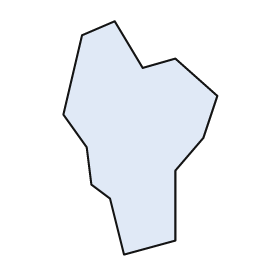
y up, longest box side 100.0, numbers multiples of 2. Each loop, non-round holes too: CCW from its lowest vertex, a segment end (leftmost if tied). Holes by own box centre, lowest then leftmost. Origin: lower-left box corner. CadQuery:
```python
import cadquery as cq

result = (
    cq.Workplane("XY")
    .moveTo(26.0, 0.0)
    .lineTo(48.0, 6.0)
    .lineTo(48.0, 36.0)
    .lineTo(60.0, 50.0)
    .lineTo(66.0, 68.0)
    .lineTo(48.0, 84.0)
    .lineTo(34.0, 80.0)
    .lineTo(22.0, 100.0)
    .lineTo(8.0, 94.0)
    .lineTo(0.0, 60.0)
    .lineTo(10.0, 46.0)
    .lineTo(12.0, 30.0)
    .lineTo(20.0, 24.0)
    .close()
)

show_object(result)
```